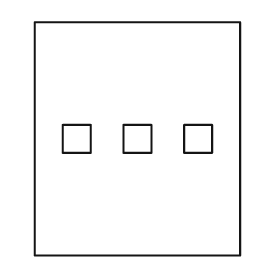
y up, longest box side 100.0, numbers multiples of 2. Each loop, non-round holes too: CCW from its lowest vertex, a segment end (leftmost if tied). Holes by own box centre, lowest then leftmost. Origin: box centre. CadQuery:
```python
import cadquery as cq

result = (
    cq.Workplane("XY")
    .moveTo(-44.0, -50.0)
    .lineTo(44.0, -50.0)
    .lineTo(44.0, 50.0)
    .lineTo(-44.0, 50.0)
    .close()
    .moveTo(-32.0, -6.0)
    .lineTo(-20.0, -6.0)
    .lineTo(-20.0, 6.0)
    .lineTo(-32.0, 6.0)
    .close()
    .moveTo(-6.0, -6.0)
    .lineTo(6.0, -6.0)
    .lineTo(6.0, 6.0)
    .lineTo(-6.0, 6.0)
    .close()
    .moveTo(20.0, -6.0)
    .lineTo(32.0, -6.0)
    .lineTo(32.0, 6.0)
    .lineTo(20.0, 6.0)
    .close()
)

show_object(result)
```